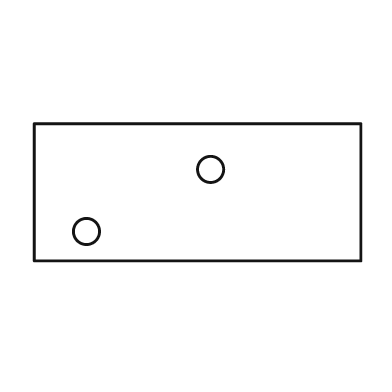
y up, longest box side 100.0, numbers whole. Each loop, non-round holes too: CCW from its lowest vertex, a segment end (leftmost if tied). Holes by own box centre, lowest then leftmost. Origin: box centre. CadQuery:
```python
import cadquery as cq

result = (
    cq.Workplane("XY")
    .moveTo(-50.0, -21.0)
    .lineTo(50.0, -21.0)
    .lineTo(50.0, 21.0)
    .lineTo(-50.0, 21.0)
    .close()
    .moveTo(-34.0, -12.0)
    .circle(4.0)
    .moveTo(4.0, 7.0)
    .circle(4.0)
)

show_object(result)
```